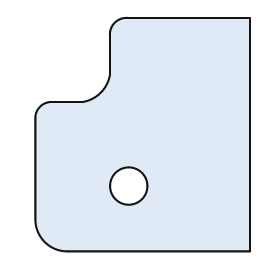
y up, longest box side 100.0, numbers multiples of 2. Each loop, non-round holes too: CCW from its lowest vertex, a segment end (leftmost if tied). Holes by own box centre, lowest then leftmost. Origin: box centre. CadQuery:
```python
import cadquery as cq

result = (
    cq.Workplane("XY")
    .moveTo(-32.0, -50.0)
    .lineTo(46.0, -50.0)
    .lineTo(46.0, 50.0)
    .lineTo(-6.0, 50.0)
    .threePointArc((-12.0, 48.0), (-14.0, 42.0))
    .lineTo(-14.0, 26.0)
    .threePointArc((-18.0, 18.0), (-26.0, 14.0))
    .lineTo(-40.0, 14.0)
    .threePointArc((-44.0, 12.0), (-46.0, 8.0))
    .lineTo(-46.0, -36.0)
    .threePointArc((-42.0, -46.0), (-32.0, -50.0))
    .close()
    .moveTo(-6.0, -22.0)
    .circle(8.0)
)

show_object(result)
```